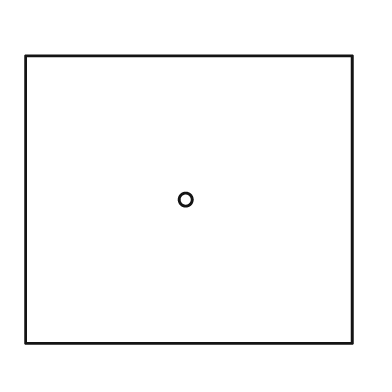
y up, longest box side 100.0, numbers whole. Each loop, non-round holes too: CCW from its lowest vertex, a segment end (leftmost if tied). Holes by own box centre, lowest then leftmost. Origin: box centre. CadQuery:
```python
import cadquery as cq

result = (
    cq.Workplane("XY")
    .moveTo(-50.0, -44.0)
    .lineTo(50.0, -44.0)
    .lineTo(50.0, 44.0)
    .lineTo(-50.0, 44.0)
    .close()
    .moveTo(-1.0, 0.0)
    .circle(2.0)
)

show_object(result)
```